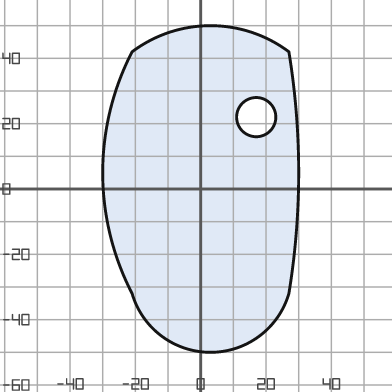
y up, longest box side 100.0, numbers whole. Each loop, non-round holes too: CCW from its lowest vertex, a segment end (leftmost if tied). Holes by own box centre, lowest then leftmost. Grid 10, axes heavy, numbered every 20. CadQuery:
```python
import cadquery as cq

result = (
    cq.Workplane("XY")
    .moveTo(-21.0, -32.0)
    .threePointArc((3.0, -50.0), (27.0, -32.0))
    .threePointArc((30.0, 5.0), (27.0, 42.0))
    .threePointArc((3.0, 50.0), (-21.0, 42.0))
    .threePointArc((-30.0, 5.0), (-21.0, -32.0))
    .close()
    .moveTo(17.0, 22.0)
    .circle(6.0)
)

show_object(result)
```